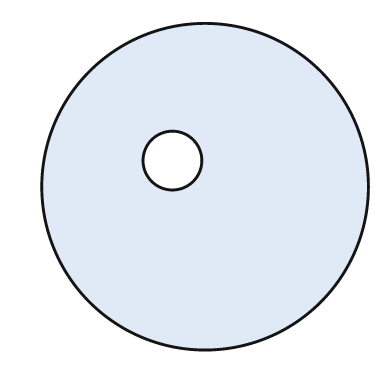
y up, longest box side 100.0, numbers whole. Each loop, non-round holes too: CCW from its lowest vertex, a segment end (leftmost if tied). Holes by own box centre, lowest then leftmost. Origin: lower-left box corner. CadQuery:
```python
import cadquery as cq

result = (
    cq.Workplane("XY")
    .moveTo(50.0, 50.0)
    .circle(50.0)
    .moveTo(40.0, 58.0)
    .circle(9.0)
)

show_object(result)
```